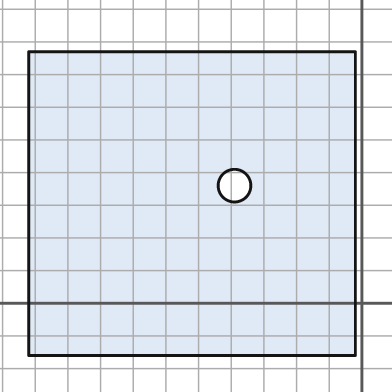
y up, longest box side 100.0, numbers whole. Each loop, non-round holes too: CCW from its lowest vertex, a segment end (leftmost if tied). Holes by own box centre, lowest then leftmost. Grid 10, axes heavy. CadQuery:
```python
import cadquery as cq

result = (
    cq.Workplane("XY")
    .moveTo(-102.0, -16.0)
    .lineTo(-2.0, -16.0)
    .lineTo(-2.0, 77.0)
    .lineTo(-102.0, 77.0)
    .close()
    .moveTo(-39.0, 36.0)
    .circle(5.0)
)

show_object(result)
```